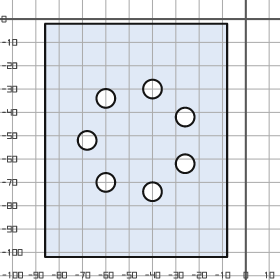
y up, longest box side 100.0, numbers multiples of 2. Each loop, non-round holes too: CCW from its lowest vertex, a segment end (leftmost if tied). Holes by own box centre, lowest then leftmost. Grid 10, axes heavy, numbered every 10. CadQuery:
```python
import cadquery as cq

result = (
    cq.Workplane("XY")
    .moveTo(-86.0, -102.0)
    .lineTo(-8.0, -102.0)
    .lineTo(-8.0, -2.0)
    .lineTo(-86.0, -2.0)
    .close()
    .moveTo(-40.0, -74.0)
    .circle(4.0)
    .moveTo(-60.0, -70.0)
    .circle(4.0)
    .moveTo(-26.0, -62.0)
    .circle(4.0)
    .moveTo(-68.0, -52.0)
    .circle(4.0)
    .moveTo(-26.0, -42.0)
    .circle(4.0)
    .moveTo(-60.0, -34.0)
    .circle(4.0)
    .moveTo(-40.0, -30.0)
    .circle(4.0)
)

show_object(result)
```